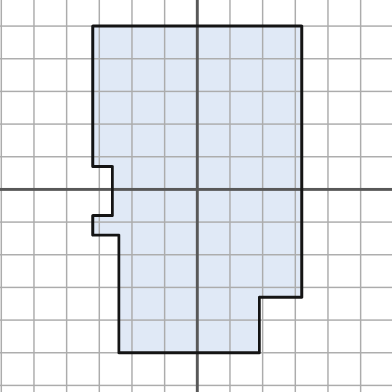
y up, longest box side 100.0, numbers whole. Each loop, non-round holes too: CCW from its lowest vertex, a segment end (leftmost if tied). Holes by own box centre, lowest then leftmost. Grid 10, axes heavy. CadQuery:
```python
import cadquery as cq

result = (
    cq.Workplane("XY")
    .moveTo(-24.0, -50.0)
    .lineTo(19.0, -50.0)
    .lineTo(19.0, -33.0)
    .lineTo(32.0, -33.0)
    .lineTo(32.0, 50.0)
    .lineTo(-32.0, 50.0)
    .lineTo(-32.0, 7.0)
    .lineTo(-26.0, 7.0)
    .lineTo(-26.0, -8.0)
    .lineTo(-32.0, -8.0)
    .lineTo(-32.0, -14.0)
    .lineTo(-24.0, -14.0)
    .close()
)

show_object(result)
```